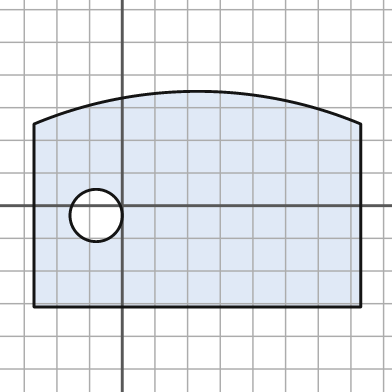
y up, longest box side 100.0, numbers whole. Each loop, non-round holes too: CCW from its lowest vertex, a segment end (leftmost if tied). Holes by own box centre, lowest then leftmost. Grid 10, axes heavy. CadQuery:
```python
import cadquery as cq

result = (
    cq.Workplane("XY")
    .moveTo(-27.0, -31.0)
    .lineTo(73.0, -31.0)
    .lineTo(73.0, 25.0)
    .threePointArc((23.0, 35.0), (-27.0, 25.0))
    .close()
    .moveTo(-8.0, -3.0)
    .circle(8.0)
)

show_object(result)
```